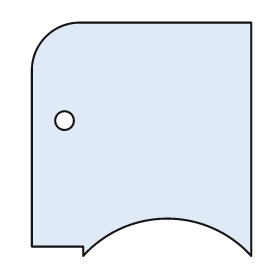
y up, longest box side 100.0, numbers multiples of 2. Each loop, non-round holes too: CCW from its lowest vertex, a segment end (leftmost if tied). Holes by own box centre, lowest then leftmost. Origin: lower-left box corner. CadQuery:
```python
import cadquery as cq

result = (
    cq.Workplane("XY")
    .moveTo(22.0, 0.0)
    .threePointArc((58.0, 16.0), (94.0, 0.0))
    .lineTo(94.0, 100.0)
    .lineTo(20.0, 100.0)
    .threePointArc((6.0, 94.0), (0.0, 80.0))
    .lineTo(0.0, 4.0)
    .lineTo(22.0, 4.0)
    .close()
    .moveTo(14.0, 58.0)
    .circle(4.0)
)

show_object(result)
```